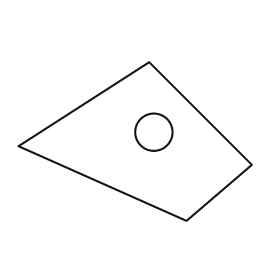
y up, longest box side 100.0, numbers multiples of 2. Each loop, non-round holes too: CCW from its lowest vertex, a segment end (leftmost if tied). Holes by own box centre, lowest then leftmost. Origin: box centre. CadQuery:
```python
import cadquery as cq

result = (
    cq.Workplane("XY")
    .moveTo(22.0, -34.0)
    .lineTo(50.0, -10.0)
    .lineTo(6.0, 34.0)
    .lineTo(-50.0, -2.0)
    .close()
    .moveTo(8.0, 4.0)
    .circle(8.0)
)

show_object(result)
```